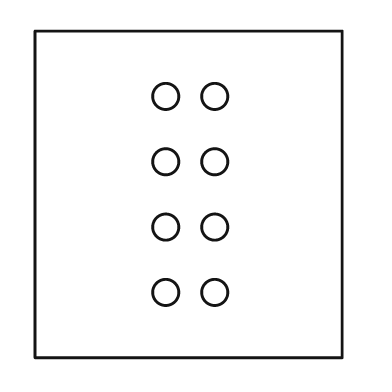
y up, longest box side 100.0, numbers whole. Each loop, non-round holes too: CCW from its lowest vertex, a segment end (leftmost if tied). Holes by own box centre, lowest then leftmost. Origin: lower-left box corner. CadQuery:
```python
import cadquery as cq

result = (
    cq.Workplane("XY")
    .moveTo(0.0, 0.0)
    .lineTo(94.0, 0.0)
    .lineTo(94.0, 100.0)
    .lineTo(0.0, 100.0)
    .close()
    .moveTo(40.0, 20.0)
    .circle(4.0)
    .moveTo(55.0, 20.0)
    .circle(4.0)
    .moveTo(40.0, 40.0)
    .circle(4.0)
    .moveTo(55.0, 40.0)
    .circle(4.0)
    .moveTo(40.0, 60.0)
    .circle(4.0)
    .moveTo(55.0, 60.0)
    .circle(4.0)
    .moveTo(40.0, 80.0)
    .circle(4.0)
    .moveTo(55.0, 80.0)
    .circle(4.0)
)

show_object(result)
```